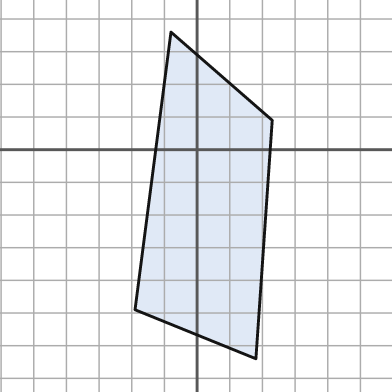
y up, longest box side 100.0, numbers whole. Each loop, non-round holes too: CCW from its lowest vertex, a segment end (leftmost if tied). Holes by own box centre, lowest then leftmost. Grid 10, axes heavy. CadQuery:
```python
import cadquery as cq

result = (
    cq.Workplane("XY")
    .moveTo(18.0, -64.0)
    .lineTo(23.0, 9.0)
    .lineTo(-8.0, 36.0)
    .lineTo(-19.0, -49.0)
    .close()
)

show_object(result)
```